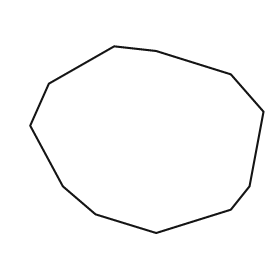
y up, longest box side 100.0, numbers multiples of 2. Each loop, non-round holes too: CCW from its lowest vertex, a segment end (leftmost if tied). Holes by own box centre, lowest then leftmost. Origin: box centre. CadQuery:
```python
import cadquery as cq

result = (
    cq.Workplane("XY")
    .moveTo(4.0, -40.0)
    .lineTo(36.0, -30.0)
    .lineTo(44.0, -20.0)
    .lineTo(50.0, 12.0)
    .lineTo(36.0, 28.0)
    .lineTo(4.0, 38.0)
    .lineTo(-14.0, 40.0)
    .lineTo(-42.0, 24.0)
    .lineTo(-50.0, 6.0)
    .lineTo(-36.0, -20.0)
    .lineTo(-22.0, -32.0)
    .close()
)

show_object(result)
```